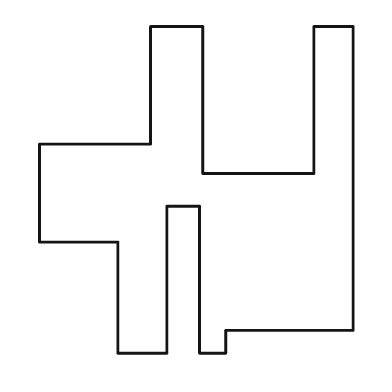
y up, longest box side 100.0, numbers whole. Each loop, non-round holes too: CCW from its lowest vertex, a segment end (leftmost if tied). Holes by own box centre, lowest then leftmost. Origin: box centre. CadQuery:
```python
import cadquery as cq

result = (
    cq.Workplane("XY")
    .moveTo(-24.0, -50.0)
    .lineTo(-9.0, -50.0)
    .lineTo(-9.0, -5.0)
    .lineTo(1.0, -5.0)
    .lineTo(1.0, -50.0)
    .lineTo(9.0, -50.0)
    .lineTo(9.0, -43.0)
    .lineTo(48.0, -43.0)
    .lineTo(48.0, 50.0)
    .lineTo(36.0, 50.0)
    .lineTo(36.0, 5.0)
    .lineTo(2.0, 5.0)
    .lineTo(2.0, 50.0)
    .lineTo(-14.0, 50.0)
    .lineTo(-14.0, 14.0)
    .lineTo(-48.0, 14.0)
    .lineTo(-48.0, -16.0)
    .lineTo(-24.0, -16.0)
    .close()
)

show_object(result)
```